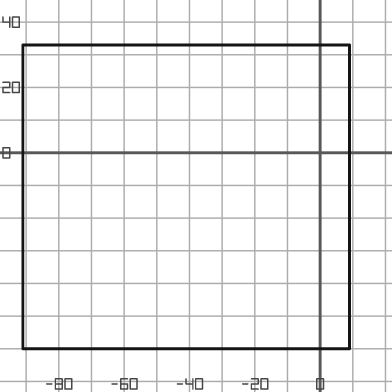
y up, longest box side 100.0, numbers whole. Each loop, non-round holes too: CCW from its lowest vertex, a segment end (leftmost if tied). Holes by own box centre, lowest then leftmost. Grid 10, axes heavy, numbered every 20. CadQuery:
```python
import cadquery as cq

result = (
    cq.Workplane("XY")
    .moveTo(-91.0, -60.0)
    .lineTo(9.0, -60.0)
    .lineTo(9.0, 33.0)
    .lineTo(-91.0, 33.0)
    .close()
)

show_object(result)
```